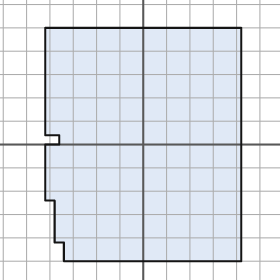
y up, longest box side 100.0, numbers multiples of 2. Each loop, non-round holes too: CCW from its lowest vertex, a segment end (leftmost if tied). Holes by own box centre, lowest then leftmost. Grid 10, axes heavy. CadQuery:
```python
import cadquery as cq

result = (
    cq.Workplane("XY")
    .moveTo(-34.0, -50.0)
    .lineTo(42.0, -50.0)
    .lineTo(42.0, 50.0)
    .lineTo(-42.0, 50.0)
    .lineTo(-42.0, 4.0)
    .lineTo(-36.0, 4.0)
    .lineTo(-36.0, 0.0)
    .lineTo(-42.0, 0.0)
    .lineTo(-42.0, -24.0)
    .lineTo(-38.0, -24.0)
    .lineTo(-38.0, -42.0)
    .lineTo(-34.0, -42.0)
    .close()
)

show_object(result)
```